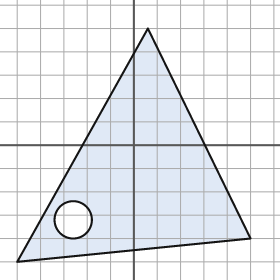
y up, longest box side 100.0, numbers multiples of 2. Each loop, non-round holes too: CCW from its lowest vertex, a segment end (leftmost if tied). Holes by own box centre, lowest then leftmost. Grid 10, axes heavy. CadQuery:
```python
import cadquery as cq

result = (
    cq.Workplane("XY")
    .moveTo(-50.0, -50.0)
    .lineTo(50.0, -40.0)
    .lineTo(6.0, 50.0)
    .close()
    .moveTo(-26.0, -32.0)
    .circle(8.0)
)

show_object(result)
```